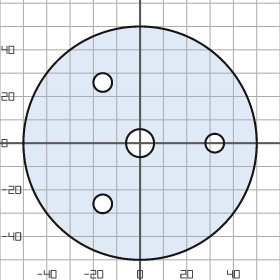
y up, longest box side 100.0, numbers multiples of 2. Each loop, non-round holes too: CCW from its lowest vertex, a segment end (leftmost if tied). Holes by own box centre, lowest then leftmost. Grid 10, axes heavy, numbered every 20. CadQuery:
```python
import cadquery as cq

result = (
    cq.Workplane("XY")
    .moveTo(0.0, 0.0)
    .circle(50.0)
    .moveTo(-16.0, -26.0)
    .circle(4.0)
    .moveTo(0.0, 0.0)
    .circle(6.0)
    .moveTo(32.0, 0.0)
    .circle(4.0)
    .moveTo(-16.0, 26.0)
    .circle(4.0)
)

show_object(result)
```